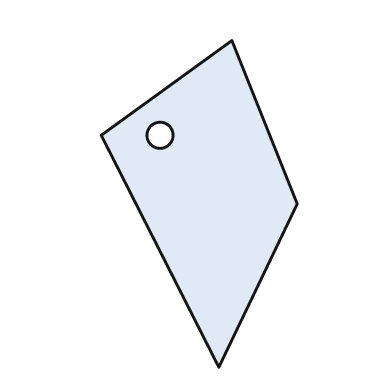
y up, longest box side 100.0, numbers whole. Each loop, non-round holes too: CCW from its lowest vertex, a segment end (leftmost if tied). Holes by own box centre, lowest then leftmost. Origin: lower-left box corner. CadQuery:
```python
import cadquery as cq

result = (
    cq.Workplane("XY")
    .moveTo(36.0, 0.0)
    .lineTo(60.0, 50.0)
    .lineTo(40.0, 100.0)
    .lineTo(0.0, 71.0)
    .close()
    .moveTo(18.0, 71.0)
    .circle(4.0)
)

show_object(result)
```